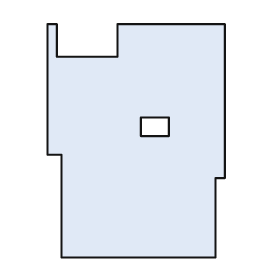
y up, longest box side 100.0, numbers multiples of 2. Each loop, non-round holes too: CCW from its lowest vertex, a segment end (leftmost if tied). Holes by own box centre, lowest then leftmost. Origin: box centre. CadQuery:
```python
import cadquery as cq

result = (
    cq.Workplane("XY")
    .moveTo(-32.0, -50.0)
    .lineTo(34.0, -50.0)
    .lineTo(34.0, -16.0)
    .lineTo(38.0, -16.0)
    .lineTo(38.0, 50.0)
    .lineTo(-8.0, 50.0)
    .lineTo(-8.0, 36.0)
    .lineTo(-34.0, 36.0)
    .lineTo(-34.0, 50.0)
    .lineTo(-38.0, 50.0)
    .lineTo(-38.0, -6.0)
    .lineTo(-32.0, -6.0)
    .close()
    .moveTo(2.0, 2.0)
    .lineTo(14.0, 2.0)
    .lineTo(14.0, 10.0)
    .lineTo(2.0, 10.0)
    .close()
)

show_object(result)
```